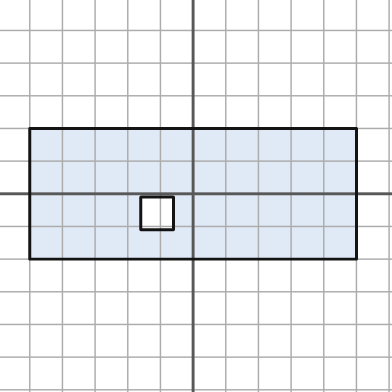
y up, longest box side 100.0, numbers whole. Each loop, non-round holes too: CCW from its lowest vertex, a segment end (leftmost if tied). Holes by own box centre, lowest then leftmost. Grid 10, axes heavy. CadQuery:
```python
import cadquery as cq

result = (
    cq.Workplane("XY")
    .moveTo(-50.0, -20.0)
    .lineTo(50.0, -20.0)
    .lineTo(50.0, 20.0)
    .lineTo(-50.0, 20.0)
    .close()
    .moveTo(-16.0, -11.0)
    .lineTo(-6.0, -11.0)
    .lineTo(-6.0, -1.0)
    .lineTo(-16.0, -1.0)
    .close()
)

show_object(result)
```